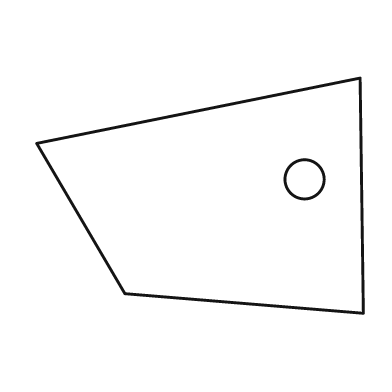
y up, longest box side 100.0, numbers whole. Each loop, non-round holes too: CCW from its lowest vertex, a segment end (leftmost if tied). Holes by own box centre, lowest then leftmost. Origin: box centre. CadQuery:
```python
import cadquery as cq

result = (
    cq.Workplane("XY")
    .moveTo(50.0, -36.0)
    .lineTo(49.0, 36.0)
    .lineTo(-50.0, 16.0)
    .lineTo(-23.0, -30.0)
    .close()
    .moveTo(32.0, 5.0)
    .circle(6.0)
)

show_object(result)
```